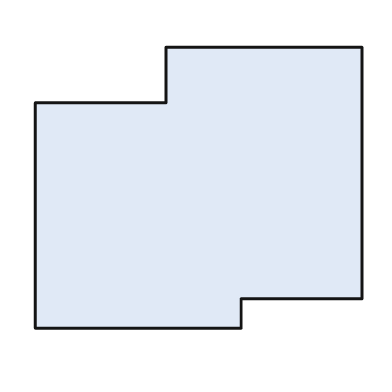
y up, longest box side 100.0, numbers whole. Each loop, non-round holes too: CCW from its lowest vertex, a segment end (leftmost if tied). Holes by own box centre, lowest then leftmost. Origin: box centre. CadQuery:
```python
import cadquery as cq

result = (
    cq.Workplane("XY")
    .moveTo(-50.0, -43.0)
    .lineTo(13.0, -43.0)
    .lineTo(13.0, -34.0)
    .lineTo(50.0, -34.0)
    .lineTo(50.0, 43.0)
    .lineTo(-10.0, 43.0)
    .lineTo(-10.0, 26.0)
    .lineTo(-50.0, 26.0)
    .close()
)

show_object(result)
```